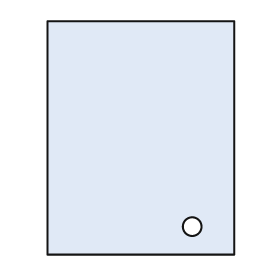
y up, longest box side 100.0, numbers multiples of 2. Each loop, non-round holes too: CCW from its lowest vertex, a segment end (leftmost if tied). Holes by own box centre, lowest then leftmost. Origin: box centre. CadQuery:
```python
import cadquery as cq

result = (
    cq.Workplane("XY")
    .moveTo(-40.0, -50.0)
    .lineTo(40.0, -50.0)
    .lineTo(40.0, 50.0)
    .lineTo(-40.0, 50.0)
    .close()
    .moveTo(22.0, -38.0)
    .circle(4.0)
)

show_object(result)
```